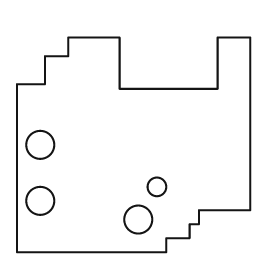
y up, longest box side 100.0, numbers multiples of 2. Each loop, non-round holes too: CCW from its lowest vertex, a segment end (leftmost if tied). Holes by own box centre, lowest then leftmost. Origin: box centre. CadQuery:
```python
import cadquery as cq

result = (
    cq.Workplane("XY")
    .moveTo(-50.0, -46.0)
    .lineTo(14.0, -46.0)
    .lineTo(14.0, -40.0)
    .lineTo(24.0, -40.0)
    .lineTo(24.0, -34.0)
    .lineTo(28.0, -34.0)
    .lineTo(28.0, -28.0)
    .lineTo(50.0, -28.0)
    .lineTo(50.0, 46.0)
    .lineTo(36.0, 46.0)
    .lineTo(36.0, 24.0)
    .lineTo(-6.0, 24.0)
    .lineTo(-6.0, 46.0)
    .lineTo(-28.0, 46.0)
    .lineTo(-28.0, 38.0)
    .lineTo(-38.0, 38.0)
    .lineTo(-38.0, 26.0)
    .lineTo(-50.0, 26.0)
    .close()
    .moveTo(2.0, -32.0)
    .circle(6.0)
    .moveTo(-40.0, -24.0)
    .circle(6.0)
    .moveTo(10.0, -18.0)
    .circle(4.0)
    .moveTo(-40.0, 0.0)
    .circle(6.0)
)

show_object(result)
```